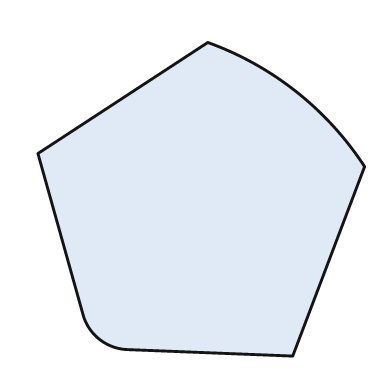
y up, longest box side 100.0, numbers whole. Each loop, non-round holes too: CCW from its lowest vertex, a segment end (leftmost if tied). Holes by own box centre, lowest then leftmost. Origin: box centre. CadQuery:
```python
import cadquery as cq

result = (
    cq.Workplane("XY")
    .moveTo(28.0, -48.0)
    .lineTo(50.0, 10.0)
    .threePointArc((29.0, 33.0), (2.0, 48.0))
    .lineTo(-50.0, 14.0)
    .lineTo(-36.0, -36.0)
    .threePointArc((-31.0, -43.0), (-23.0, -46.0))
    .close()
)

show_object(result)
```